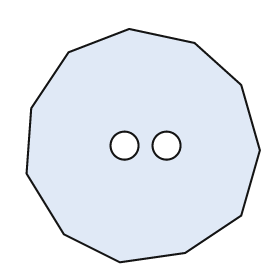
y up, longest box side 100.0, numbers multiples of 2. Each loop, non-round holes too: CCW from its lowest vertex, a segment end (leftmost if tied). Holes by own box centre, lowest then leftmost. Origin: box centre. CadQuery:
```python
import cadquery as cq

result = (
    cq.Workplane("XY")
    .moveTo(-10.0, -50.0)
    .lineTo(18.0, -46.0)
    .lineTo(42.0, -30.0)
    .lineTo(50.0, -2.0)
    .lineTo(42.0, 26.0)
    .lineTo(22.0, 44.0)
    .lineTo(-6.0, 50.0)
    .lineTo(-32.0, 40.0)
    .lineTo(-48.0, 16.0)
    .lineTo(-50.0, -12.0)
    .lineTo(-34.0, -38.0)
    .close()
    .moveTo(-8.0, 0.0)
    .circle(6.0)
    .moveTo(10.0, 0.0)
    .circle(6.0)
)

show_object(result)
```